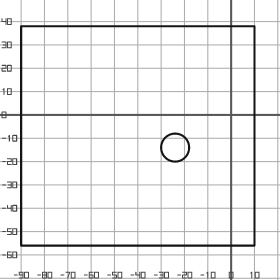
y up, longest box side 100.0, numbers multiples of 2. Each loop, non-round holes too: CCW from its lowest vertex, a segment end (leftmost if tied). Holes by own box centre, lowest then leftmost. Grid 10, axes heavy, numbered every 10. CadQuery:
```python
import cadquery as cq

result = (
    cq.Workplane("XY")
    .moveTo(-90.0, -56.0)
    .lineTo(10.0, -56.0)
    .lineTo(10.0, 38.0)
    .lineTo(-90.0, 38.0)
    .close()
    .moveTo(-24.0, -14.0)
    .circle(6.0)
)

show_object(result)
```